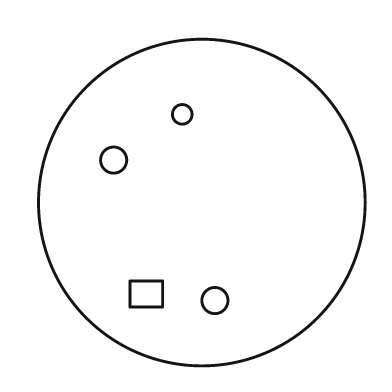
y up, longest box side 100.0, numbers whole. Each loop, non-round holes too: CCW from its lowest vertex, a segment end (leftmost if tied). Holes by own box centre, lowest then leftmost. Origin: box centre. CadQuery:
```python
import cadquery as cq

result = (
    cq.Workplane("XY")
    .moveTo(0.0, 0.0)
    .circle(50.0)
    .moveTo(4.0, -30.0)
    .circle(4.0)
    .moveTo(-22.0, -32.0)
    .lineTo(-12.0, -32.0)
    .lineTo(-12.0, -24.0)
    .lineTo(-22.0, -24.0)
    .close()
    .moveTo(-27.0, 13.0)
    .circle(4.0)
    .moveTo(-6.0, 27.0)
    .circle(3.0)
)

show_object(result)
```